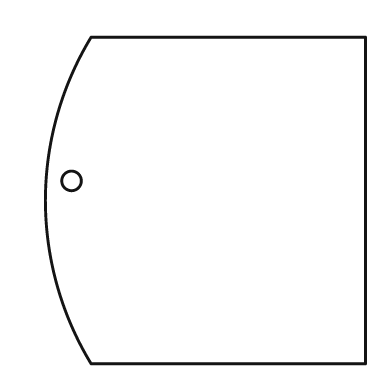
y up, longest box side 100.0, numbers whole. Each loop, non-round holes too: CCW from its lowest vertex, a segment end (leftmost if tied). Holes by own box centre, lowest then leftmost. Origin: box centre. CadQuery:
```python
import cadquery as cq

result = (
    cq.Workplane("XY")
    .moveTo(-35.0, -50.0)
    .lineTo(49.0, -50.0)
    .lineTo(49.0, 50.0)
    .lineTo(-35.0, 50.0)
    .threePointArc((-49.0, 0.0), (-35.0, -50.0))
    .close()
    .moveTo(-41.0, 6.0)
    .circle(3.0)
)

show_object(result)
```